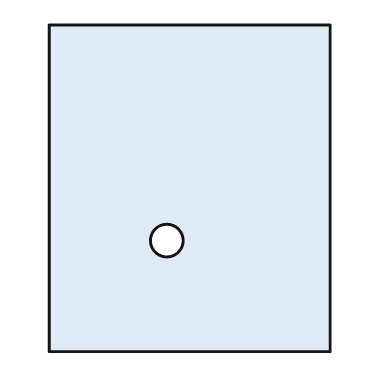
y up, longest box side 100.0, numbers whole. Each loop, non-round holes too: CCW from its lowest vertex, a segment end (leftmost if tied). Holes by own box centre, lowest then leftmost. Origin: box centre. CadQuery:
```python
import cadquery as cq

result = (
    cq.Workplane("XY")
    .moveTo(-43.0, -50.0)
    .lineTo(43.0, -50.0)
    .lineTo(43.0, 50.0)
    .lineTo(-43.0, 50.0)
    .close()
    .moveTo(-7.0, -16.0)
    .circle(5.0)
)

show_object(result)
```